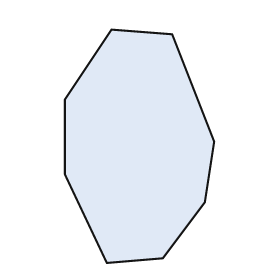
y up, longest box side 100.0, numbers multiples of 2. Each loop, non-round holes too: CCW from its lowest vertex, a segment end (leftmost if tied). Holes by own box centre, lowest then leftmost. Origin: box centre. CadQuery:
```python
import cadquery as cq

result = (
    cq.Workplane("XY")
    .moveTo(-14.0, -50.0)
    .lineTo(10.0, -48.0)
    .lineTo(28.0, -24.0)
    .lineTo(32.0, 2.0)
    .lineTo(14.0, 48.0)
    .lineTo(-12.0, 50.0)
    .lineTo(-32.0, 20.0)
    .lineTo(-32.0, -12.0)
    .close()
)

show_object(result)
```